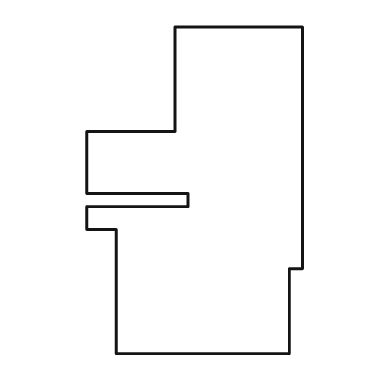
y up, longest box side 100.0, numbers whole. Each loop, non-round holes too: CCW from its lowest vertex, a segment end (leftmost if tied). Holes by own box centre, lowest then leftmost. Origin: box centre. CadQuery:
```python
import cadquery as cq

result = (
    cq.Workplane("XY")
    .moveTo(-24.0, -50.0)
    .lineTo(29.0, -50.0)
    .lineTo(29.0, -24.0)
    .lineTo(33.0, -24.0)
    .lineTo(33.0, 50.0)
    .lineTo(-6.0, 50.0)
    .lineTo(-6.0, 18.0)
    .lineTo(-33.0, 18.0)
    .lineTo(-33.0, -1.0)
    .lineTo(-2.0, -1.0)
    .lineTo(-2.0, -5.0)
    .lineTo(-33.0, -5.0)
    .lineTo(-33.0, -12.0)
    .lineTo(-24.0, -12.0)
    .close()
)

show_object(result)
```